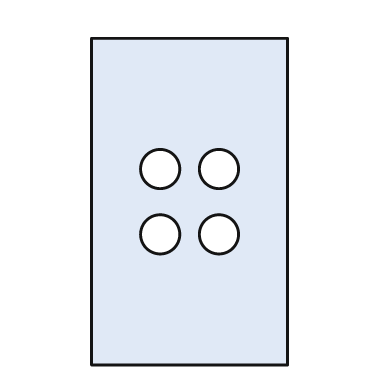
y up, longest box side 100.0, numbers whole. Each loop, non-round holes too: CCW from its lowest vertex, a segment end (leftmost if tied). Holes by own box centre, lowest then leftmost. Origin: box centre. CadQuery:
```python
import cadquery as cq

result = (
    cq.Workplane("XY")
    .moveTo(-30.0, -50.0)
    .lineTo(30.0, -50.0)
    .lineTo(30.0, 50.0)
    .lineTo(-30.0, 50.0)
    .close()
    .moveTo(-9.0, -10.0)
    .circle(6.0)
    .moveTo(9.0, -10.0)
    .circle(6.0)
    .moveTo(-9.0, 10.0)
    .circle(6.0)
    .moveTo(9.0, 10.0)
    .circle(6.0)
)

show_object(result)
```